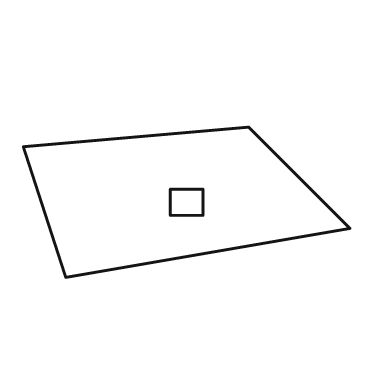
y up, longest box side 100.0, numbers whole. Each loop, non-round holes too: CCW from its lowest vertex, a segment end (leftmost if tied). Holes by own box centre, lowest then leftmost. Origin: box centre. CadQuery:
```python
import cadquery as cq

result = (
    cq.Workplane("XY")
    .moveTo(-37.0, -23.0)
    .lineTo(50.0, -8.0)
    .lineTo(19.0, 23.0)
    .lineTo(-50.0, 17.0)
    .close()
    .moveTo(-5.0, -4.0)
    .lineTo(5.0, -4.0)
    .lineTo(5.0, 4.0)
    .lineTo(-5.0, 4.0)
    .close()
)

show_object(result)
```